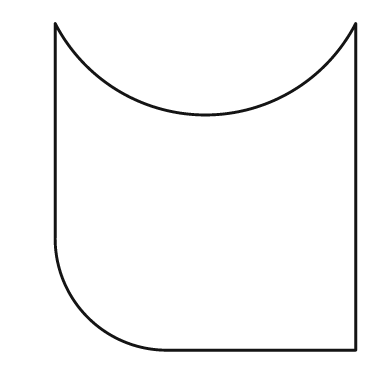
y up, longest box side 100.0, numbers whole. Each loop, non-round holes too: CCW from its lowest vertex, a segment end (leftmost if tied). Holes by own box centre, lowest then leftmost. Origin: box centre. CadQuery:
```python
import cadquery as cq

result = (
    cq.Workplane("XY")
    .moveTo(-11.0, -50.0)
    .lineTo(46.0, -50.0)
    .lineTo(46.0, 50.0)
    .threePointArc((0.0, 22.0), (-46.0, 50.0))
    .lineTo(-46.0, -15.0)
    .threePointArc((-36.0, -40.0), (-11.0, -50.0))
    .close()
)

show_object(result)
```